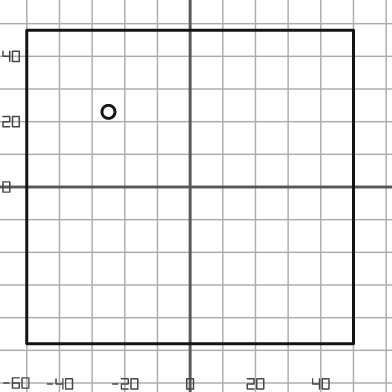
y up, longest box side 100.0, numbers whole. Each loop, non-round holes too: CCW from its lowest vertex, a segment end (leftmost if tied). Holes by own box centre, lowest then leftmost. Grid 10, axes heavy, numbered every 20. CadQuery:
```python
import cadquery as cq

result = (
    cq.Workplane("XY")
    .moveTo(-50.0, -48.0)
    .lineTo(50.0, -48.0)
    .lineTo(50.0, 48.0)
    .lineTo(-50.0, 48.0)
    .close()
    .moveTo(-25.0, 23.0)
    .circle(2.0)
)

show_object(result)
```